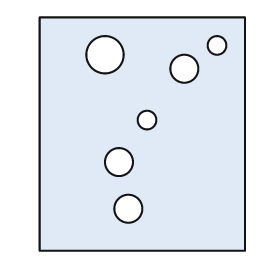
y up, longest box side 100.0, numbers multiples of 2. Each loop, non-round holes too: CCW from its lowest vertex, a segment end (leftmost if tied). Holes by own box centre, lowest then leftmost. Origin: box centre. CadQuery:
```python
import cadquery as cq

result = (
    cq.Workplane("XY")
    .moveTo(-44.0, -50.0)
    .lineTo(44.0, -50.0)
    .lineTo(44.0, 50.0)
    .lineTo(-44.0, 50.0)
    .close()
    .moveTo(-6.0, -32.0)
    .circle(6.0)
    .moveTo(-10.0, -12.0)
    .circle(6.0)
    .moveTo(2.0, 6.0)
    .circle(4.0)
    .moveTo(18.0, 28.0)
    .circle(6.0)
    .moveTo(-16.0, 34.0)
    .circle(8.0)
    .moveTo(32.0, 38.0)
    .circle(4.0)
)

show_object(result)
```